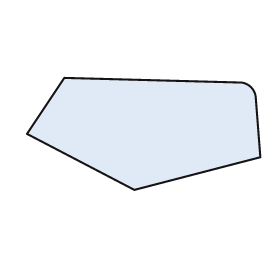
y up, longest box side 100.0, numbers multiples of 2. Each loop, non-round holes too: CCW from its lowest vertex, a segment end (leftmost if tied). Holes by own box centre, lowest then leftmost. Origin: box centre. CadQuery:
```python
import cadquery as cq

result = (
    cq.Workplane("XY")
    .moveTo(-4.0, -24.0)
    .lineTo(50.0, -10.0)
    .lineTo(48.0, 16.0)
    .threePointArc((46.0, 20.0), (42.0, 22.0))
    .lineTo(-34.0, 24.0)
    .lineTo(-50.0, 0.0)
    .close()
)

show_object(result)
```